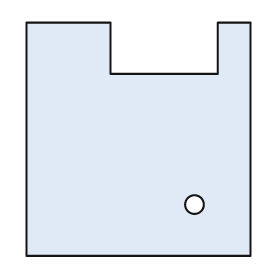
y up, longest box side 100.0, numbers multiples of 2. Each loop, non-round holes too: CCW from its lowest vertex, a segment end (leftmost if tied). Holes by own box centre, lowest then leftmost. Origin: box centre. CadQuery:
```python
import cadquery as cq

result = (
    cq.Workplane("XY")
    .moveTo(-48.0, -50.0)
    .lineTo(48.0, -50.0)
    .lineTo(48.0, 50.0)
    .lineTo(34.0, 50.0)
    .lineTo(34.0, 28.0)
    .lineTo(-12.0, 28.0)
    .lineTo(-12.0, 50.0)
    .lineTo(-48.0, 50.0)
    .close()
    .moveTo(24.0, -28.0)
    .circle(4.0)
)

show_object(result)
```